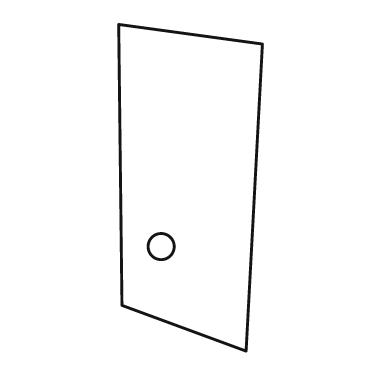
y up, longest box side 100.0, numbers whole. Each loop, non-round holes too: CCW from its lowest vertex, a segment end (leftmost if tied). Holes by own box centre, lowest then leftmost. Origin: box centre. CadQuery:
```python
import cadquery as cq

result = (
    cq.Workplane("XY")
    .moveTo(17.0, -50.0)
    .lineTo(22.0, 44.0)
    .lineTo(-22.0, 50.0)
    .lineTo(-21.0, -36.0)
    .close()
    .moveTo(-9.0, -18.0)
    .circle(4.0)
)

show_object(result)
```